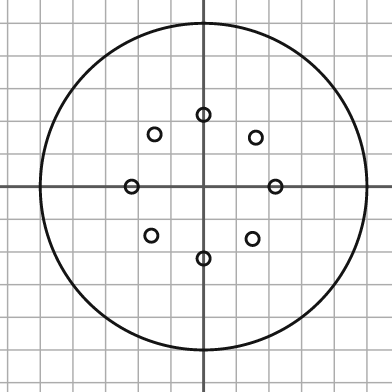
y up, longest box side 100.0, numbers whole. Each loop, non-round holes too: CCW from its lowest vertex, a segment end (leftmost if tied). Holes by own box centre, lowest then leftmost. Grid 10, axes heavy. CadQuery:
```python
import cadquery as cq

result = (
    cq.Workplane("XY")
    .moveTo(0.0, 0.0)
    .circle(50.0)
    .moveTo(0.0, -22.0)
    .circle(2.0)
    .moveTo(15.0, -16.0)
    .circle(2.0)
    .moveTo(-16.0, -15.0)
    .circle(2.0)
    .moveTo(-22.0, 0.0)
    .circle(2.0)
    .moveTo(22.0, 0.0)
    .circle(2.0)
    .moveTo(16.0, 15.0)
    .circle(2.0)
    .moveTo(-15.0, 16.0)
    .circle(2.0)
    .moveTo(0.0, 22.0)
    .circle(2.0)
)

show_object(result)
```